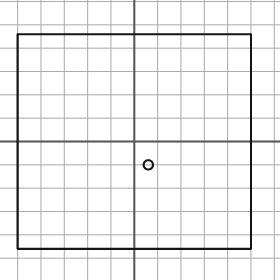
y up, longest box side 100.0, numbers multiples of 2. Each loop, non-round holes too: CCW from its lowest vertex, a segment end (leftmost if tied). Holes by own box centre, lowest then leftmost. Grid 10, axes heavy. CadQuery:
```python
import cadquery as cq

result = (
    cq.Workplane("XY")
    .moveTo(-50.0, -46.0)
    .lineTo(50.0, -46.0)
    .lineTo(50.0, 46.0)
    .lineTo(-50.0, 46.0)
    .close()
    .moveTo(6.0, -10.0)
    .circle(2.0)
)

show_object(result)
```